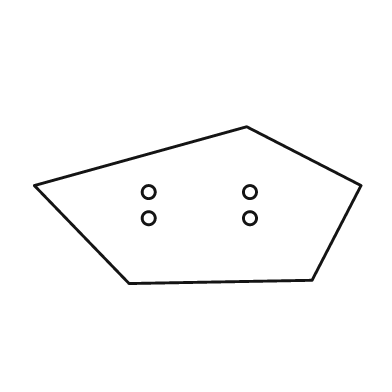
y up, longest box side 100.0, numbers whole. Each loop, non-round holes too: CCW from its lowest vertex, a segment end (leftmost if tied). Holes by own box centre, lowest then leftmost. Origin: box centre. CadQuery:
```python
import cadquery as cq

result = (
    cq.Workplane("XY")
    .moveTo(-21.0, -24.0)
    .lineTo(35.0, -23.0)
    .lineTo(50.0, 6.0)
    .lineTo(15.0, 24.0)
    .lineTo(-50.0, 6.0)
    .close()
    .moveTo(-15.0, -4.0)
    .circle(2.0)
    .moveTo(16.0, -4.0)
    .circle(2.0)
    .moveTo(-15.0, 4.0)
    .circle(2.0)
    .moveTo(16.0, 4.0)
    .circle(2.0)
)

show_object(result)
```